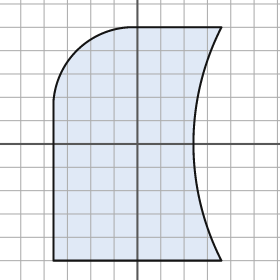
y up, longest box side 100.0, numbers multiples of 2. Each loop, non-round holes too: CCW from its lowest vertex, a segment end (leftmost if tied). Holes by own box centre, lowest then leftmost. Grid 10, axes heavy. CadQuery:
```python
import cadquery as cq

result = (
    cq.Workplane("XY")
    .moveTo(-36.0, -50.0)
    .lineTo(36.0, -50.0)
    .threePointArc((24.0, 0.0), (36.0, 50.0))
    .lineTo(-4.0, 50.0)
    .threePointArc((-26.0, 40.0), (-36.0, 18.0))
    .close()
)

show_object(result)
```